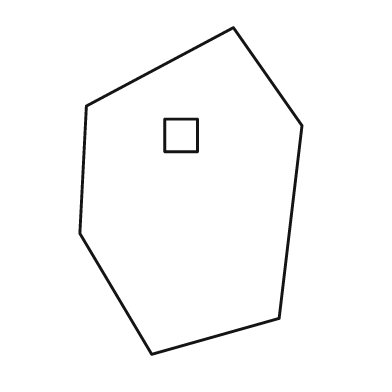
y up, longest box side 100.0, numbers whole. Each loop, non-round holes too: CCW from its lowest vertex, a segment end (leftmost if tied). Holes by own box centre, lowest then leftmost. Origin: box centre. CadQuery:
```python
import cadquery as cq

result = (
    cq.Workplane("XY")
    .moveTo(-12.0, -50.0)
    .lineTo(27.0, -39.0)
    .lineTo(34.0, 20.0)
    .lineTo(13.0, 50.0)
    .lineTo(-32.0, 26.0)
    .lineTo(-34.0, -13.0)
    .close()
    .moveTo(-8.0, 12.0)
    .lineTo(2.0, 12.0)
    .lineTo(2.0, 22.0)
    .lineTo(-8.0, 22.0)
    .close()
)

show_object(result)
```